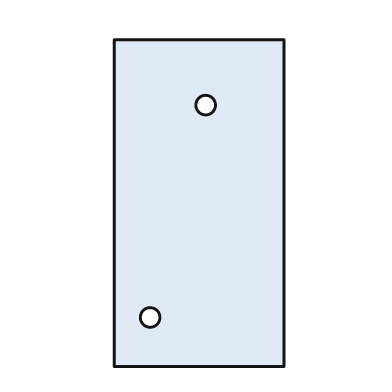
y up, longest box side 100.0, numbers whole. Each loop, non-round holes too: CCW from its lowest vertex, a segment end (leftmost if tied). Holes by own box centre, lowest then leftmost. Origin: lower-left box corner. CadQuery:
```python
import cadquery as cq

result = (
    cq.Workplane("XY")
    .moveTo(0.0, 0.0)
    .lineTo(52.0, 0.0)
    .lineTo(52.0, 100.0)
    .lineTo(0.0, 100.0)
    .close()
    .moveTo(11.0, 15.0)
    .circle(3.0)
    .moveTo(28.0, 80.0)
    .circle(3.0)
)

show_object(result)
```